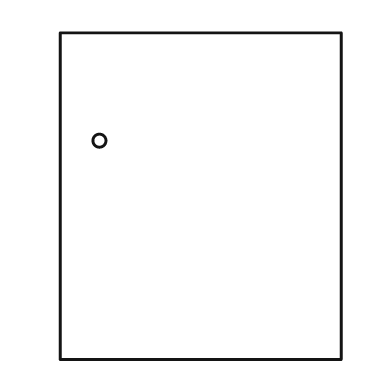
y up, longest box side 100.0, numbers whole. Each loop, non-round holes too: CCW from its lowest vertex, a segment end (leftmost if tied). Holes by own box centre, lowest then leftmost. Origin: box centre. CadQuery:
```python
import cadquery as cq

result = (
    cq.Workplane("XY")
    .moveTo(-43.0, -50.0)
    .lineTo(43.0, -50.0)
    .lineTo(43.0, 50.0)
    .lineTo(-43.0, 50.0)
    .close()
    .moveTo(-31.0, 17.0)
    .circle(2.0)
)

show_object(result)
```